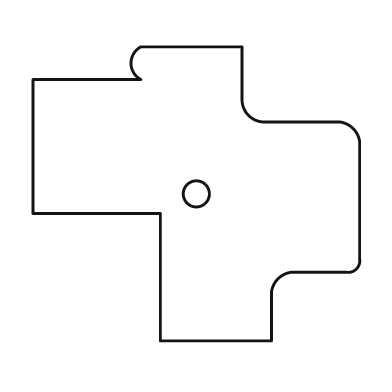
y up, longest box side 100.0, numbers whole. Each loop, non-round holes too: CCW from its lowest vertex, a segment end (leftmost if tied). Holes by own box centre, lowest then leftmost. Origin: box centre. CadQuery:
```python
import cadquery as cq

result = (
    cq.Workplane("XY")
    .moveTo(-11.0, -45.0)
    .lineTo(23.0, -45.0)
    .lineTo(23.0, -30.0)
    .threePointArc((25.0, -26.0), (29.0, -24.0))
    .lineTo(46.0, -24.0)
    .threePointArc((49.0, -23.0), (50.0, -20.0))
    .lineTo(50.0, 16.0)
    .threePointArc((48.0, 20.0), (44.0, 22.0))
    .lineTo(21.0, 22.0)
    .threePointArc((16.0, 24.0), (14.0, 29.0))
    .lineTo(14.0, 45.0)
    .lineTo(-17.0, 45.0)
    .threePointArc((-20.0, 40.0), (-17.0, 35.0))
    .lineTo(-50.0, 35.0)
    .lineTo(-50.0, -6.0)
    .lineTo(-11.0, -6.0)
    .close()
    .moveTo(0.0, 0.0)
    .circle(4.0)
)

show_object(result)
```